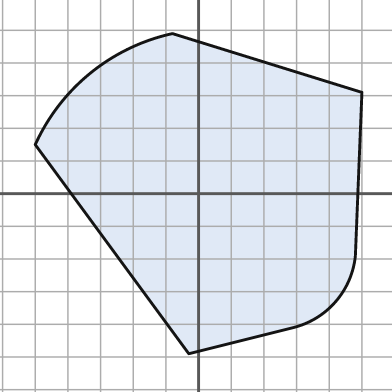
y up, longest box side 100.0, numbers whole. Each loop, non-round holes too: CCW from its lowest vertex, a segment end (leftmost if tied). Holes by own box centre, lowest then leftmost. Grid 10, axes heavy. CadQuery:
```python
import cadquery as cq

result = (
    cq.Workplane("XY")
    .moveTo(-3.0, -49.0)
    .lineTo(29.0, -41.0)
    .threePointArc((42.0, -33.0), (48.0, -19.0))
    .lineTo(50.0, 31.0)
    .lineTo(-8.0, 49.0)
    .threePointArc((-33.0, 37.0), (-50.0, 15.0))
    .close()
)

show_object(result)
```